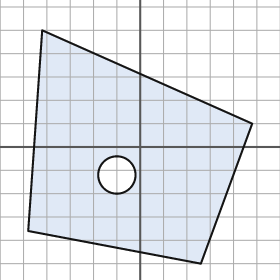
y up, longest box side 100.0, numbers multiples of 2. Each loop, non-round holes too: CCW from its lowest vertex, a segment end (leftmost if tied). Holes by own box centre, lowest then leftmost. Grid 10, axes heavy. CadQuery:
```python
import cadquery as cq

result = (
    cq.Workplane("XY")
    .moveTo(26.0, -50.0)
    .lineTo(48.0, 10.0)
    .lineTo(-42.0, 50.0)
    .lineTo(-48.0, -36.0)
    .close()
    .moveTo(-10.0, -12.0)
    .circle(8.0)
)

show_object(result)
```